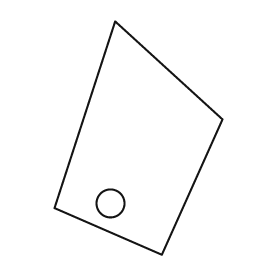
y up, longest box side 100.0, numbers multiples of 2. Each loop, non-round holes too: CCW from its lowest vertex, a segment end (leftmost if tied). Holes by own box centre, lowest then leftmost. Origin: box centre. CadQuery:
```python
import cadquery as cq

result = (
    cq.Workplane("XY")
    .moveTo(10.0, -50.0)
    .lineTo(36.0, 8.0)
    .lineTo(-10.0, 50.0)
    .lineTo(-36.0, -30.0)
    .close()
    .moveTo(-12.0, -28.0)
    .circle(6.0)
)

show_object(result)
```